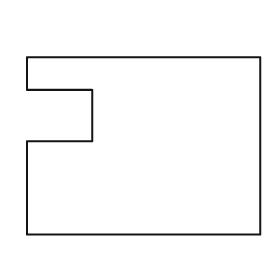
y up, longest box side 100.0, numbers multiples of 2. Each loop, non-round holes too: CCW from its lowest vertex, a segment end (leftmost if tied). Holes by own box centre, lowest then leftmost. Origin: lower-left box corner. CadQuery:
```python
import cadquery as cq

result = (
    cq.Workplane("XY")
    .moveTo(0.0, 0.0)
    .lineTo(100.0, 0.0)
    .lineTo(100.0, 76.0)
    .lineTo(0.0, 76.0)
    .lineTo(0.0, 62.0)
    .lineTo(28.0, 62.0)
    .lineTo(28.0, 40.0)
    .lineTo(0.0, 40.0)
    .close()
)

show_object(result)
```